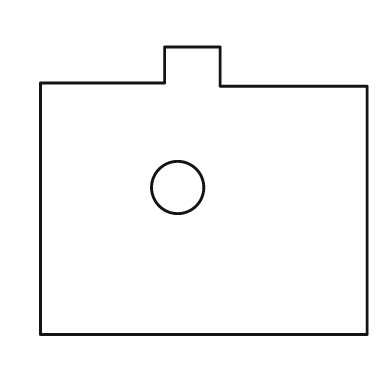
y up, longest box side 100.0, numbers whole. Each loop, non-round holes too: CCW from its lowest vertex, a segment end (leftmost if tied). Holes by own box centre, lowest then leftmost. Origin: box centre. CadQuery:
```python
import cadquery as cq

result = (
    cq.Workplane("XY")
    .moveTo(-50.0, -44.0)
    .lineTo(50.0, -44.0)
    .lineTo(50.0, 32.0)
    .lineTo(5.0, 32.0)
    .lineTo(5.0, 44.0)
    .lineTo(-12.0, 44.0)
    .lineTo(-12.0, 33.0)
    .lineTo(-50.0, 33.0)
    .close()
    .moveTo(-8.0, 1.0)
    .circle(8.0)
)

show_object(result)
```